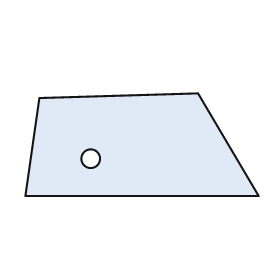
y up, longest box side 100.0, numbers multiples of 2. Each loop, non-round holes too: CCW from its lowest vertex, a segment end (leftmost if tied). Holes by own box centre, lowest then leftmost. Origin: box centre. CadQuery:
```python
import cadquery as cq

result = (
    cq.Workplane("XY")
    .moveTo(-50.0, -22.0)
    .lineTo(50.0, -22.0)
    .lineTo(24.0, 22.0)
    .lineTo(-44.0, 20.0)
    .close()
    .moveTo(-22.0, -6.0)
    .circle(4.0)
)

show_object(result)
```